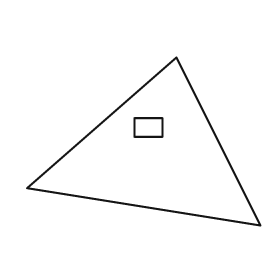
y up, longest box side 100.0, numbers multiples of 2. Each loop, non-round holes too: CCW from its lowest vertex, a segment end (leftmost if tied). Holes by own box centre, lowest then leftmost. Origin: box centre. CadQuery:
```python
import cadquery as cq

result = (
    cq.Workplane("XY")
    .moveTo(50.0, -36.0)
    .lineTo(14.0, 36.0)
    .lineTo(-50.0, -20.0)
    .close()
    .moveTo(-4.0, 2.0)
    .lineTo(8.0, 2.0)
    .lineTo(8.0, 10.0)
    .lineTo(-4.0, 10.0)
    .close()
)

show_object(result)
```